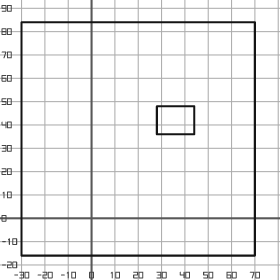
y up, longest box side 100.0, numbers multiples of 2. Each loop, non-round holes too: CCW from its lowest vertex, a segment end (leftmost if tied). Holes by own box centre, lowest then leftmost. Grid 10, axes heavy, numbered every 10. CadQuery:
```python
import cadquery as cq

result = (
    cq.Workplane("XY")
    .moveTo(-30.0, -16.0)
    .lineTo(70.0, -16.0)
    .lineTo(70.0, 84.0)
    .lineTo(-30.0, 84.0)
    .close()
    .moveTo(28.0, 36.0)
    .lineTo(44.0, 36.0)
    .lineTo(44.0, 48.0)
    .lineTo(28.0, 48.0)
    .close()
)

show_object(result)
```